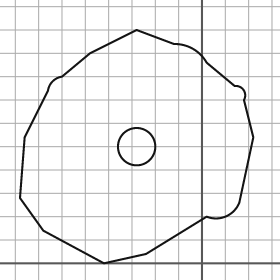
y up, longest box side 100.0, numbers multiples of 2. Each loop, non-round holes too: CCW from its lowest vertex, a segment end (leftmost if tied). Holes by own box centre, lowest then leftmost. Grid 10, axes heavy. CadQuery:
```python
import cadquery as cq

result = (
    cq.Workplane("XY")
    .moveTo(-42.0, 0.0)
    .lineTo(-24.0, 4.0)
    .lineTo(2.0, 20.0)
    .threePointArc((10.0, 20.0), (16.0, 26.0))
    .lineTo(22.0, 54.0)
    .lineTo(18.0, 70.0)
    .threePointArc((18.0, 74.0), (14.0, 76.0))
    .lineTo(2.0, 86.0)
    .threePointArc((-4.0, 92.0), (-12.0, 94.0))
    .lineTo(-28.0, 100.0)
    .lineTo(-48.0, 90.0)
    .lineTo(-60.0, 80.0)
    .threePointArc((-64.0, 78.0), (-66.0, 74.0))
    .lineTo(-76.0, 54.0)
    .lineTo(-78.0, 28.0)
    .lineTo(-68.0, 14.0)
    .close()
    .moveTo(-28.0, 50.0)
    .circle(8.0)
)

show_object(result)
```